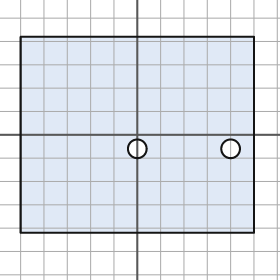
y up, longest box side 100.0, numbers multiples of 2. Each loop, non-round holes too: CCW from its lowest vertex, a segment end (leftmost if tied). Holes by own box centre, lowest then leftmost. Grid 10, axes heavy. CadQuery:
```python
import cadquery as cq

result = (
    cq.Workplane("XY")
    .moveTo(-50.0, -42.0)
    .lineTo(50.0, -42.0)
    .lineTo(50.0, 42.0)
    .lineTo(-50.0, 42.0)
    .close()
    .moveTo(0.0, -6.0)
    .circle(4.0)
    .moveTo(40.0, -6.0)
    .circle(4.0)
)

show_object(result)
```